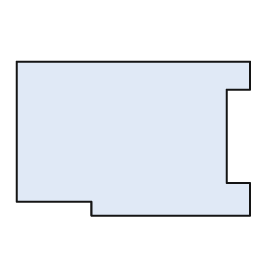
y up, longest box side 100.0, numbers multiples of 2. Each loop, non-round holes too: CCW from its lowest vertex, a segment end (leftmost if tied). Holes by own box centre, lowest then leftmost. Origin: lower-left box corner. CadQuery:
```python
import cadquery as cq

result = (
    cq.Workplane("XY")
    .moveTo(32.0, 0.0)
    .lineTo(100.0, 0.0)
    .lineTo(100.0, 14.0)
    .lineTo(90.0, 14.0)
    .lineTo(90.0, 54.0)
    .lineTo(100.0, 54.0)
    .lineTo(100.0, 66.0)
    .lineTo(0.0, 66.0)
    .lineTo(0.0, 6.0)
    .lineTo(32.0, 6.0)
    .close()
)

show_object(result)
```